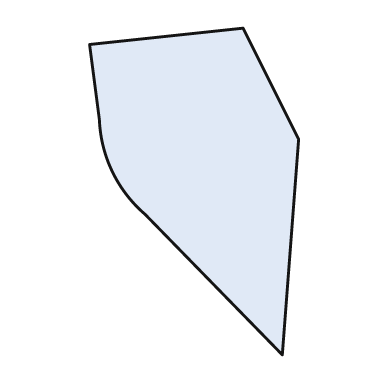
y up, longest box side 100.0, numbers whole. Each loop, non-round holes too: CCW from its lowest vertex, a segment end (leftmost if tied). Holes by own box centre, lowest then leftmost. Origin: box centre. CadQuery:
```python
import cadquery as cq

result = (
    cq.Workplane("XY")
    .moveTo(27.0, -50.0)
    .lineTo(32.0, 16.0)
    .lineTo(15.0, 50.0)
    .lineTo(-32.0, 45.0)
    .lineTo(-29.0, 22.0)
    .threePointArc((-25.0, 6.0), (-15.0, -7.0))
    .close()
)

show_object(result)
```